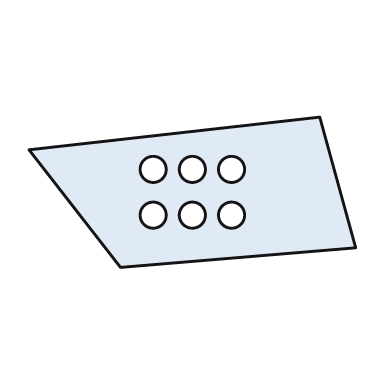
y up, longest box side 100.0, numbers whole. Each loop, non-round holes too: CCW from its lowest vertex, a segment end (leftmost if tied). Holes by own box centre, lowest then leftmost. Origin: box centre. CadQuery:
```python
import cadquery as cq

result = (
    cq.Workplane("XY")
    .moveTo(-22.0, -23.0)
    .lineTo(50.0, -17.0)
    .lineTo(39.0, 23.0)
    .lineTo(-50.0, 13.0)
    .close()
    .moveTo(-12.0, -7.0)
    .circle(4.0)
    .moveTo(0.0, -7.0)
    .circle(4.0)
    .moveTo(12.0, -7.0)
    .circle(4.0)
    .moveTo(-12.0, 7.0)
    .circle(4.0)
    .moveTo(0.0, 7.0)
    .circle(4.0)
    .moveTo(12.0, 7.0)
    .circle(4.0)
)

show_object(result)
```